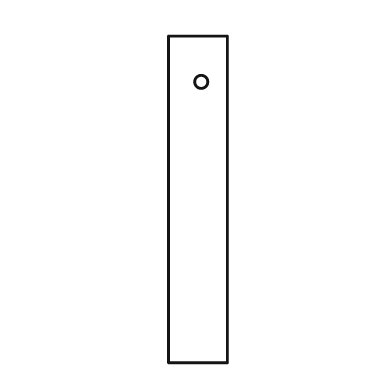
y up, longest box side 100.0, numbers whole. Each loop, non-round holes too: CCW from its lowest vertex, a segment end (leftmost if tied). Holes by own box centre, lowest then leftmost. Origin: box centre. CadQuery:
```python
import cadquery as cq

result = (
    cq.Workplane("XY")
    .moveTo(-9.0, -50.0)
    .lineTo(9.0, -50.0)
    .lineTo(9.0, 50.0)
    .lineTo(-9.0, 50.0)
    .close()
    .moveTo(1.0, 36.0)
    .circle(2.0)
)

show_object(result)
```